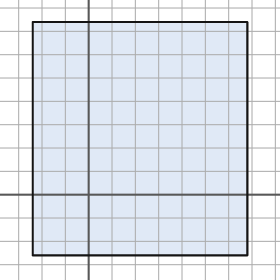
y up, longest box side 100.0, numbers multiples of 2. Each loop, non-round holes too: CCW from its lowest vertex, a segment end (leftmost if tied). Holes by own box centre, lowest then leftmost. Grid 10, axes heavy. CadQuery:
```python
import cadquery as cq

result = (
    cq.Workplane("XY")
    .moveTo(-24.0, -26.0)
    .lineTo(68.0, -26.0)
    .lineTo(68.0, 74.0)
    .lineTo(-24.0, 74.0)
    .close()
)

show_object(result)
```